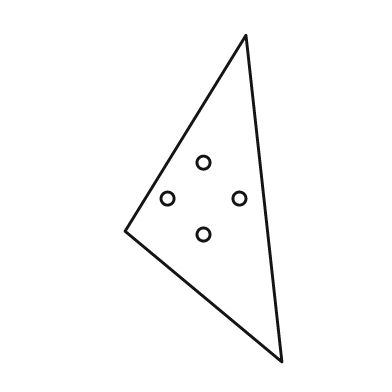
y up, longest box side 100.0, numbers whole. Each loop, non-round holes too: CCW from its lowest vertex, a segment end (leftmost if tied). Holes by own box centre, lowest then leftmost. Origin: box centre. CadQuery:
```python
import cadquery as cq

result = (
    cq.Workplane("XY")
    .moveTo(24.0, -50.0)
    .lineTo(13.0, 50.0)
    .lineTo(-24.0, -10.0)
    .close()
    .moveTo(0.0, -11.0)
    .circle(2.0)
    .moveTo(-11.0, 0.0)
    .circle(2.0)
    .moveTo(11.0, 0.0)
    .circle(2.0)
    .moveTo(0.0, 11.0)
    .circle(2.0)
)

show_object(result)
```